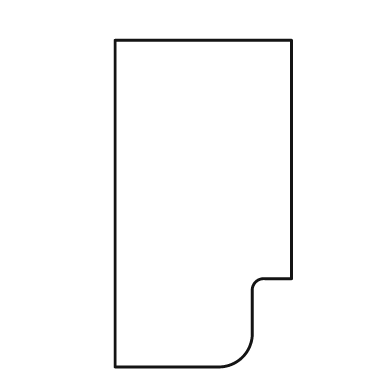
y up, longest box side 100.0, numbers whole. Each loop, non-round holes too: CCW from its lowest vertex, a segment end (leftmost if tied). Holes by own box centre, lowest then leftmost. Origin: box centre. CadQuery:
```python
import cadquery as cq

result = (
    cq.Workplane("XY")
    .moveTo(-27.0, -50.0)
    .lineTo(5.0, -50.0)
    .threePointArc((12.0, -47.0), (15.0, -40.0))
    .lineTo(15.0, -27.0)
    .threePointArc((16.0, -24.0), (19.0, -23.0))
    .lineTo(27.0, -23.0)
    .lineTo(27.0, 50.0)
    .lineTo(-27.0, 50.0)
    .close()
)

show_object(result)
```